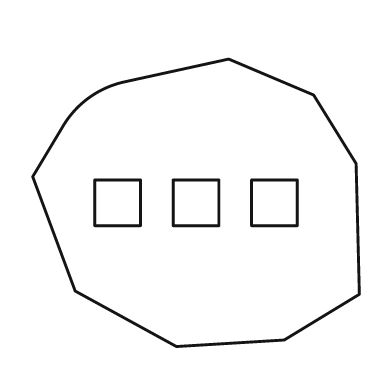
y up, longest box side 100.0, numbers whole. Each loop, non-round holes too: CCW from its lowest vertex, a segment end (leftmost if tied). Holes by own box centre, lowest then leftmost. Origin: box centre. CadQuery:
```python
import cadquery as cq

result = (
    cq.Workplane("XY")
    .moveTo(-6.0, -44.0)
    .lineTo(27.0, -42.0)
    .lineTo(50.0, -28.0)
    .lineTo(49.0, 12.0)
    .lineTo(36.0, 33.0)
    .lineTo(10.0, 44.0)
    .lineTo(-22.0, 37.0)
    .threePointArc((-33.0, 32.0), (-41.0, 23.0))
    .lineTo(-50.0, 8.0)
    .lineTo(-37.0, -27.0)
    .close()
    .moveTo(-31.0, -7.0)
    .lineTo(-17.0, -7.0)
    .lineTo(-17.0, 7.0)
    .lineTo(-31.0, 7.0)
    .close()
    .moveTo(-7.0, -7.0)
    .lineTo(7.0, -7.0)
    .lineTo(7.0, 7.0)
    .lineTo(-7.0, 7.0)
    .close()
    .moveTo(17.0, -7.0)
    .lineTo(31.0, -7.0)
    .lineTo(31.0, 7.0)
    .lineTo(17.0, 7.0)
    .close()
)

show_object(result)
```